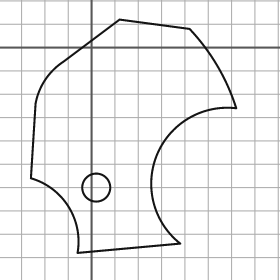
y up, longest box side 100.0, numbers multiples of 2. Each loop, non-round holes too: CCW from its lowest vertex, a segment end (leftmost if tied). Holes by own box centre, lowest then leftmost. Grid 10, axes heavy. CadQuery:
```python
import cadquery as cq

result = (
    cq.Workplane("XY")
    .moveTo(-6.0, -88.0)
    .lineTo(38.0, -84.0)
    .threePointArc((28.0, -46.0), (62.0, -26.0))
    .threePointArc((54.0, -8.0), (42.0, 8.0))
    .lineTo(12.0, 12.0)
    .lineTo(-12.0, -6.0)
    .threePointArc((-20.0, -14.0), (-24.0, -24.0))
    .lineTo(-26.0, -56.0)
    .threePointArc((-10.0, -68.0), (-6.0, -88.0))
    .close()
    .moveTo(2.0, -60.0)
    .circle(6.0)
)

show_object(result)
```